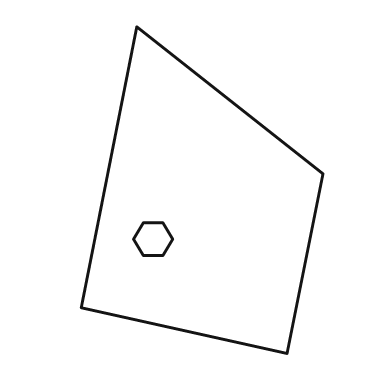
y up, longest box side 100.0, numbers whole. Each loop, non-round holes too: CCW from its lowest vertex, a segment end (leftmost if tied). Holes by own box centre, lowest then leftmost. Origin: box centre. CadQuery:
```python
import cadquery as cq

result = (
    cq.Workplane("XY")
    .moveTo(26.0, -50.0)
    .lineTo(37.0, 5.0)
    .lineTo(-20.0, 50.0)
    .lineTo(-37.0, -36.0)
    .close()
    .moveTo(-18.0, -20.0)
    .lineTo(-12.0, -20.0)
    .lineTo(-9.0, -15.0)
    .lineTo(-12.0, -10.0)
    .lineTo(-18.0, -10.0)
    .lineTo(-21.0, -15.0)
    .close()
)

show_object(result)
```